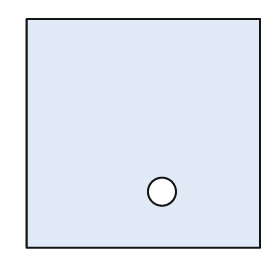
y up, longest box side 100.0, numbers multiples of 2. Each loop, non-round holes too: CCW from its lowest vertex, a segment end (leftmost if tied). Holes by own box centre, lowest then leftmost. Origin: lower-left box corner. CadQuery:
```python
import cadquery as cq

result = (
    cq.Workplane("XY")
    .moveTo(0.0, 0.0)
    .lineTo(100.0, 0.0)
    .lineTo(100.0, 98.0)
    .lineTo(0.0, 98.0)
    .close()
    .moveTo(58.0, 24.0)
    .circle(6.0)
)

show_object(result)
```